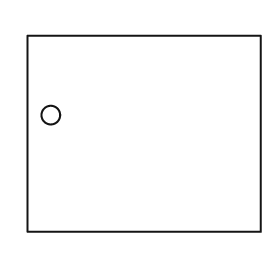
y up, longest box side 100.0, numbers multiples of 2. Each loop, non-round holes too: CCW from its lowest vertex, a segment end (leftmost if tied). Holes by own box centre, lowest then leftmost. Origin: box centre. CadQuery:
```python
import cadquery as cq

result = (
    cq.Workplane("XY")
    .moveTo(-50.0, -42.0)
    .lineTo(50.0, -42.0)
    .lineTo(50.0, 42.0)
    .lineTo(-50.0, 42.0)
    .close()
    .moveTo(-40.0, 8.0)
    .circle(4.0)
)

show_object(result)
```